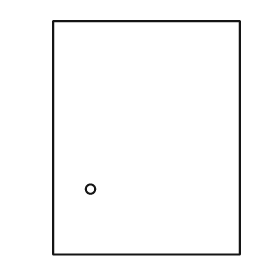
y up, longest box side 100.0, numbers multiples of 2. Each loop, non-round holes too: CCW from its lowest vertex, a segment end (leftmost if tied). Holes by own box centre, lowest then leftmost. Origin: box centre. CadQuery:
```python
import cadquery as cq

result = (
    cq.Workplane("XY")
    .moveTo(-40.0, -50.0)
    .lineTo(40.0, -50.0)
    .lineTo(40.0, 50.0)
    .lineTo(-40.0, 50.0)
    .close()
    .moveTo(-24.0, -22.0)
    .circle(2.0)
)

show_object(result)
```